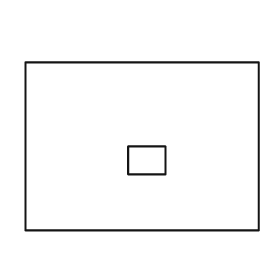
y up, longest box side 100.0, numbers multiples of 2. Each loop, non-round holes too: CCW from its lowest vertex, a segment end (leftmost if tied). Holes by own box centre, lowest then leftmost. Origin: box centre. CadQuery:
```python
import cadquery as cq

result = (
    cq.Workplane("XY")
    .moveTo(-50.0, -36.0)
    .lineTo(50.0, -36.0)
    .lineTo(50.0, 36.0)
    .lineTo(-50.0, 36.0)
    .close()
    .moveTo(-6.0, -12.0)
    .lineTo(10.0, -12.0)
    .lineTo(10.0, 0.0)
    .lineTo(-6.0, 0.0)
    .close()
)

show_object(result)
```